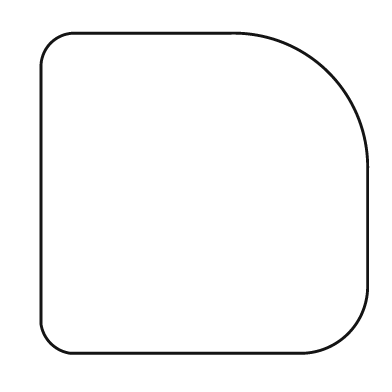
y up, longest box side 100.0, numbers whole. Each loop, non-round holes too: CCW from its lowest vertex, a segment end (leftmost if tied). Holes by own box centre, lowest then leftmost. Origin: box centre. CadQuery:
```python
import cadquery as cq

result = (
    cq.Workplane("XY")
    .moveTo(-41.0, -49.0)
    .lineTo(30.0, -49.0)
    .threePointArc((44.0, -43.0), (50.0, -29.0))
    .lineTo(50.0, 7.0)
    .threePointArc((38.0, 37.0), (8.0, 49.0))
    .lineTo(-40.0, 49.0)
    .threePointArc((-47.0, 46.0), (-50.0, 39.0))
    .lineTo(-50.0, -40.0)
    .threePointArc((-47.0, -46.0), (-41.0, -49.0))
    .close()
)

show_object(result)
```